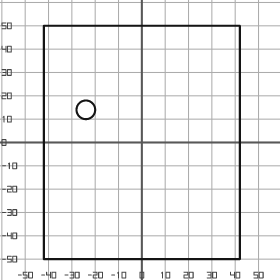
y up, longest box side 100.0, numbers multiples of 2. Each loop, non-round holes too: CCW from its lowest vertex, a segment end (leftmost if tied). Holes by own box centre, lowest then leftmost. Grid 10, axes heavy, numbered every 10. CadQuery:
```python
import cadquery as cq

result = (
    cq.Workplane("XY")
    .moveTo(-42.0, -50.0)
    .lineTo(42.0, -50.0)
    .lineTo(42.0, 50.0)
    .lineTo(-42.0, 50.0)
    .close()
    .moveTo(-24.0, 14.0)
    .circle(4.0)
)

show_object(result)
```